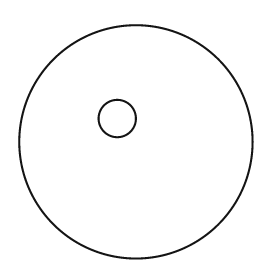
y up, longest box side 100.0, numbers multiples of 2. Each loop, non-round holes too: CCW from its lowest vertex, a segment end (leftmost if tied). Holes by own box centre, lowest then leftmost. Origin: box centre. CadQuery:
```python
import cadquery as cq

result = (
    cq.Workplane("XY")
    .moveTo(0.0, 0.0)
    .circle(50.0)
    .moveTo(-8.0, 10.0)
    .circle(8.0)
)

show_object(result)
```